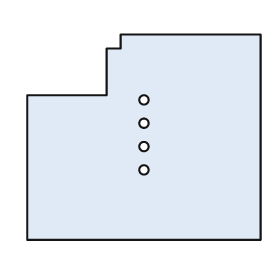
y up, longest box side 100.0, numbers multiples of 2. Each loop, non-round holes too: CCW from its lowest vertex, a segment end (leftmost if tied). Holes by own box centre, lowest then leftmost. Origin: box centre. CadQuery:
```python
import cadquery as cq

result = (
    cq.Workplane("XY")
    .moveTo(-50.0, -44.0)
    .lineTo(50.0, -44.0)
    .lineTo(50.0, 44.0)
    .lineTo(-10.0, 44.0)
    .lineTo(-10.0, 38.0)
    .lineTo(-16.0, 38.0)
    .lineTo(-16.0, 18.0)
    .lineTo(-50.0, 18.0)
    .close()
    .moveTo(0.0, -14.0)
    .circle(2.0)
    .moveTo(0.0, -4.0)
    .circle(2.0)
    .moveTo(0.0, 6.0)
    .circle(2.0)
    .moveTo(0.0, 16.0)
    .circle(2.0)
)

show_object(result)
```